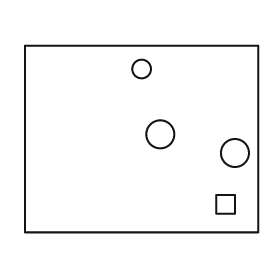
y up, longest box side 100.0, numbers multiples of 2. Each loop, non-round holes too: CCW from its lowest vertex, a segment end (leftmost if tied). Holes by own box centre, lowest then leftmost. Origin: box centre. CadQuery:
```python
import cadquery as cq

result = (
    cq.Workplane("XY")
    .moveTo(-50.0, -40.0)
    .lineTo(50.0, -40.0)
    .lineTo(50.0, 40.0)
    .lineTo(-50.0, 40.0)
    .close()
    .moveTo(32.0, -32.0)
    .lineTo(40.0, -32.0)
    .lineTo(40.0, -24.0)
    .lineTo(32.0, -24.0)
    .close()
    .moveTo(40.0, -6.0)
    .circle(6.0)
    .moveTo(8.0, 2.0)
    .circle(6.0)
    .moveTo(0.0, 30.0)
    .circle(4.0)
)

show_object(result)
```